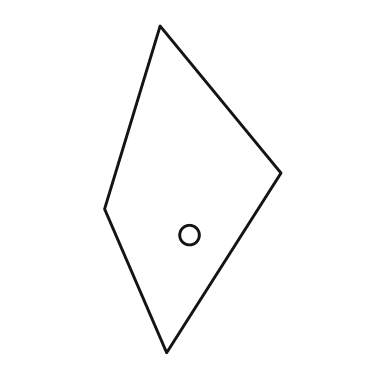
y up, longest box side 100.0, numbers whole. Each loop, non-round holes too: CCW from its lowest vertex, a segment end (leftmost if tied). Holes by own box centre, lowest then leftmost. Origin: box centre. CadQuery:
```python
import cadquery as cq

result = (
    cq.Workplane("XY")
    .moveTo(-8.0, -50.0)
    .lineTo(27.0, 5.0)
    .lineTo(-10.0, 50.0)
    .lineTo(-27.0, -6.0)
    .close()
    .moveTo(-1.0, -14.0)
    .circle(3.0)
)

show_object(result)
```